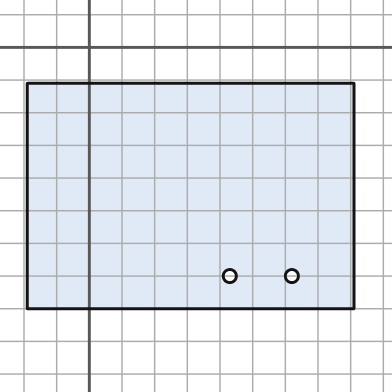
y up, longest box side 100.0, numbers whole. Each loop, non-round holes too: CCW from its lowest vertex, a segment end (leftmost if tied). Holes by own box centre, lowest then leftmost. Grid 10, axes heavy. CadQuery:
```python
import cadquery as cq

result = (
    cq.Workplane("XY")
    .moveTo(-19.0, -80.0)
    .lineTo(81.0, -80.0)
    .lineTo(81.0, -11.0)
    .lineTo(-19.0, -11.0)
    .close()
    .moveTo(43.0, -70.0)
    .circle(2.0)
    .moveTo(62.0, -70.0)
    .circle(2.0)
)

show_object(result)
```